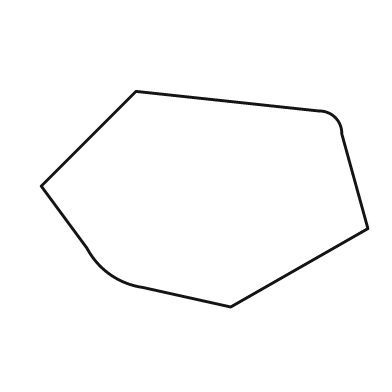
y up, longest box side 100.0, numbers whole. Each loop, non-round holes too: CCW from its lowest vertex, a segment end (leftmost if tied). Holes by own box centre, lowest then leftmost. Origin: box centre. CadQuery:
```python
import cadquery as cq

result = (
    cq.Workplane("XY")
    .moveTo(8.0, -33.0)
    .lineTo(50.0, -9.0)
    .lineTo(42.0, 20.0)
    .threePointArc((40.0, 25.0), (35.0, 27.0))
    .lineTo(-21.0, 33.0)
    .lineTo(-50.0, 4.0)
    .lineTo(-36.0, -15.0)
    .threePointArc((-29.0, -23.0), (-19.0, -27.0))
    .close()
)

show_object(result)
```